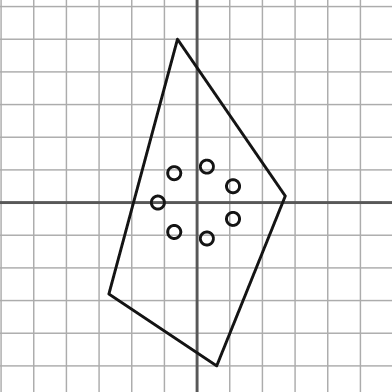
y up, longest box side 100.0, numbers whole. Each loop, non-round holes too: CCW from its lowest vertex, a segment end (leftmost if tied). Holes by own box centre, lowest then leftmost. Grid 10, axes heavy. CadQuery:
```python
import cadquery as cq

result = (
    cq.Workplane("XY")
    .moveTo(6.0, -50.0)
    .lineTo(27.0, 2.0)
    .lineTo(-6.0, 50.0)
    .lineTo(-27.0, -28.0)
    .close()
    .moveTo(3.0, -11.0)
    .circle(2.0)
    .moveTo(-7.0, -9.0)
    .circle(2.0)
    .moveTo(11.0, -5.0)
    .circle(2.0)
    .moveTo(-12.0, 0.0)
    .circle(2.0)
    .moveTo(11.0, 5.0)
    .circle(2.0)
    .moveTo(-7.0, 9.0)
    .circle(2.0)
    .moveTo(3.0, 11.0)
    .circle(2.0)
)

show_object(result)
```